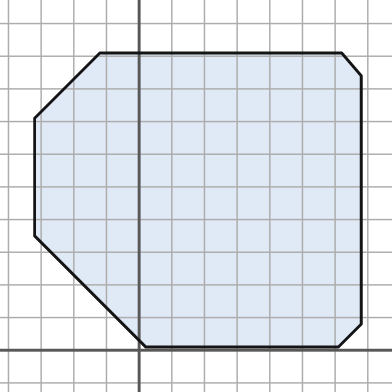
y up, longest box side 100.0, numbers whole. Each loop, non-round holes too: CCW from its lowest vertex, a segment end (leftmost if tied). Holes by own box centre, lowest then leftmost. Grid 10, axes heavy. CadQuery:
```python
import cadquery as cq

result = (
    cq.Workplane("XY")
    .moveTo(2.0, 1.0)
    .lineTo(61.0, 1.0)
    .lineTo(68.0, 8.0)
    .lineTo(68.0, 84.0)
    .lineTo(62.0, 91.0)
    .lineTo(-12.0, 91.0)
    .lineTo(-32.0, 71.0)
    .lineTo(-32.0, 35.0)
    .close()
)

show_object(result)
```